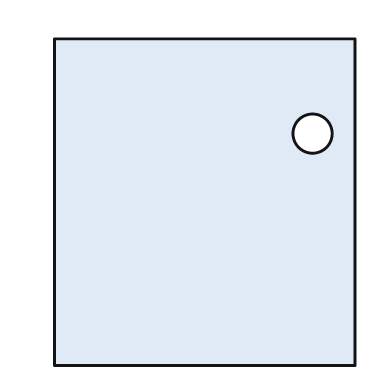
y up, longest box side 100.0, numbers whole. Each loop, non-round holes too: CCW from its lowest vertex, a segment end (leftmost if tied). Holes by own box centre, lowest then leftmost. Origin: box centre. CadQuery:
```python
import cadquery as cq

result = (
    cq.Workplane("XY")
    .moveTo(-46.0, -50.0)
    .lineTo(46.0, -50.0)
    .lineTo(46.0, 50.0)
    .lineTo(-46.0, 50.0)
    .close()
    .moveTo(33.0, 21.0)
    .circle(6.0)
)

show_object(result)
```